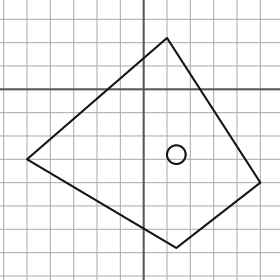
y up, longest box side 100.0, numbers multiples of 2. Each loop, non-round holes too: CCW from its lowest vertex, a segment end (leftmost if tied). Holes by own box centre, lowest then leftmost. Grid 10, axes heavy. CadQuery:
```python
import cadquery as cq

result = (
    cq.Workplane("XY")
    .moveTo(14.0, -68.0)
    .lineTo(50.0, -40.0)
    .lineTo(10.0, 22.0)
    .lineTo(-50.0, -30.0)
    .close()
    .moveTo(14.0, -28.0)
    .circle(4.0)
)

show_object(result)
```